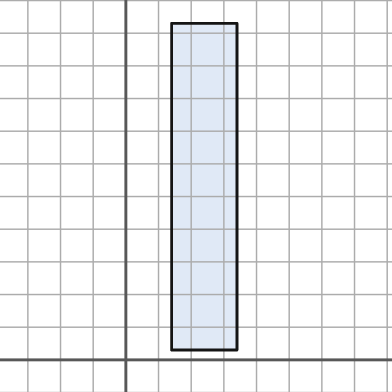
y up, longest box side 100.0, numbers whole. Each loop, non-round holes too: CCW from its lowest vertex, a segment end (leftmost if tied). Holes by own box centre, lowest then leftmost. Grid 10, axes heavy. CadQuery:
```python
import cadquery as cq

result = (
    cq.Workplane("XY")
    .moveTo(14.0, 3.0)
    .lineTo(34.0, 3.0)
    .lineTo(34.0, 103.0)
    .lineTo(14.0, 103.0)
    .close()
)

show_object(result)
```